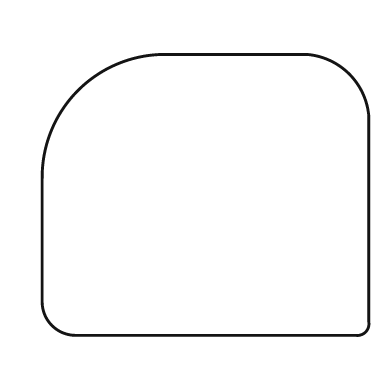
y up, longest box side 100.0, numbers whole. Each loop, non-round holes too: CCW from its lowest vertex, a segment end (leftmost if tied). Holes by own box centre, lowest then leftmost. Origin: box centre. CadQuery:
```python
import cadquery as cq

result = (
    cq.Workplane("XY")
    .moveTo(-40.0, -43.0)
    .lineTo(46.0, -43.0)
    .threePointArc((49.0, -42.0), (50.0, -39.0))
    .lineTo(50.0, 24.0)
    .threePointArc((44.0, 37.0), (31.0, 43.0))
    .lineTo(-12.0, 43.0)
    .threePointArc((-39.0, 32.0), (-50.0, 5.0))
    .lineTo(-50.0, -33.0)
    .threePointArc((-47.0, -40.0), (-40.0, -43.0))
    .close()
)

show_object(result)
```